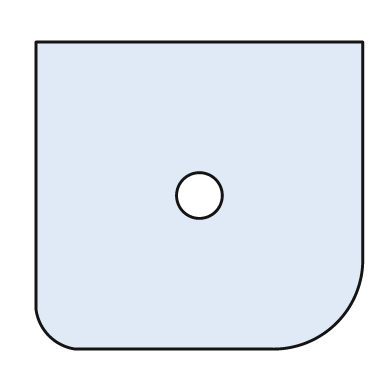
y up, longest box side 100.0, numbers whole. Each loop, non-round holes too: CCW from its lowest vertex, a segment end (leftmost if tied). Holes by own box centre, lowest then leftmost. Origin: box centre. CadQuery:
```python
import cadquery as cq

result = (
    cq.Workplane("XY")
    .moveTo(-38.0, -47.0)
    .lineTo(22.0, -47.0)
    .threePointArc((42.0, -39.0), (50.0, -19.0))
    .lineTo(50.0, 47.0)
    .lineTo(-50.0, 47.0)
    .lineTo(-50.0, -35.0)
    .threePointArc((-46.0, -43.0), (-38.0, -47.0))
    .close()
    .moveTo(0.0, 0.0)
    .circle(7.0)
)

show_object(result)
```